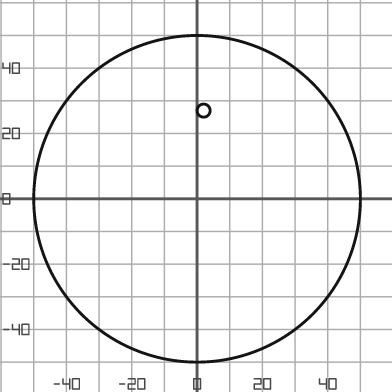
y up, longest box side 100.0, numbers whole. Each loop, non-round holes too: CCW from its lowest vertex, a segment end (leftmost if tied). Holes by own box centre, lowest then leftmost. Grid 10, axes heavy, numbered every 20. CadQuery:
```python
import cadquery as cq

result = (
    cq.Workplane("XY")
    .moveTo(0.0, 0.0)
    .circle(50.0)
    .moveTo(2.0, 27.0)
    .circle(2.0)
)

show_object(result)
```